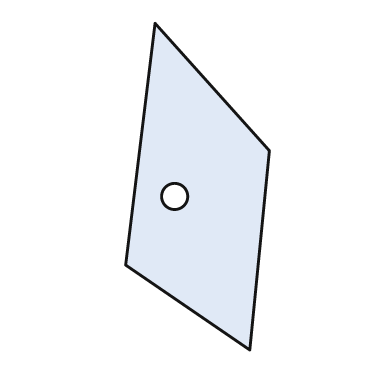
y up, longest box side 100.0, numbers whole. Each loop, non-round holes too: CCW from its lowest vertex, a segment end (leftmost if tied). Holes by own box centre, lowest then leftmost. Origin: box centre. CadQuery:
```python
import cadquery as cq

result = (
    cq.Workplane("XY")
    .moveTo(16.0, -50.0)
    .lineTo(22.0, 11.0)
    .lineTo(-13.0, 50.0)
    .lineTo(-22.0, -24.0)
    .close()
    .moveTo(-7.0, -3.0)
    .circle(4.0)
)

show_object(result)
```